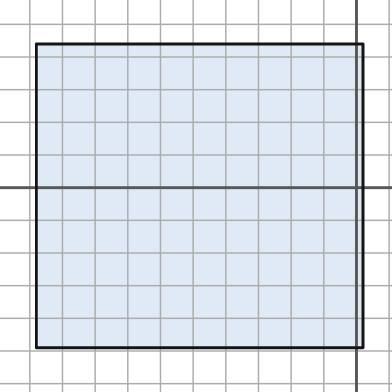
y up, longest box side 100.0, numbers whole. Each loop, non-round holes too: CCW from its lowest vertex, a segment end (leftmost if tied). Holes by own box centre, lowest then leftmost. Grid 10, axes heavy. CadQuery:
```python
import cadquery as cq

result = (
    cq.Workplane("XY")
    .moveTo(-98.0, -49.0)
    .lineTo(2.0, -49.0)
    .lineTo(2.0, 44.0)
    .lineTo(-98.0, 44.0)
    .close()
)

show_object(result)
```